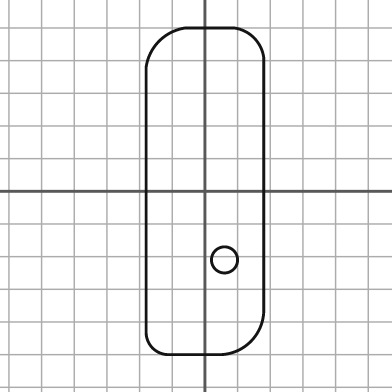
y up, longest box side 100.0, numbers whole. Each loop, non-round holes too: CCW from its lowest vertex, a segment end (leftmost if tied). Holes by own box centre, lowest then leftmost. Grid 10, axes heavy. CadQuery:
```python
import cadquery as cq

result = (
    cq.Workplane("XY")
    .moveTo(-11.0, -50.0)
    .lineTo(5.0, -50.0)
    .threePointArc((14.0, -46.0), (18.0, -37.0))
    .lineTo(18.0, 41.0)
    .threePointArc((15.0, 47.0), (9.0, 50.0))
    .lineTo(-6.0, 50.0)
    .threePointArc((-14.0, 46.0), (-18.0, 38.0))
    .lineTo(-18.0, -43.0)
    .threePointArc((-16.0, -48.0), (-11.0, -50.0))
    .close()
    .moveTo(6.0, -21.0)
    .circle(4.0)
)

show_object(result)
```